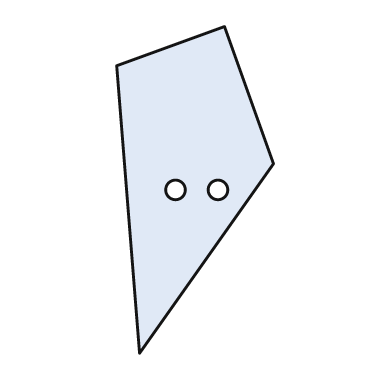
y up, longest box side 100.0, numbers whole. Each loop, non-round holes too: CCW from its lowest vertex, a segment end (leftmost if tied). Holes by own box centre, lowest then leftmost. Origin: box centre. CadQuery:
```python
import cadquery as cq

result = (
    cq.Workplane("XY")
    .moveTo(-17.0, -50.0)
    .lineTo(24.0, 8.0)
    .lineTo(9.0, 50.0)
    .lineTo(-24.0, 38.0)
    .close()
    .moveTo(-6.0, 0.0)
    .circle(3.0)
    .moveTo(7.0, 0.0)
    .circle(3.0)
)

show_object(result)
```